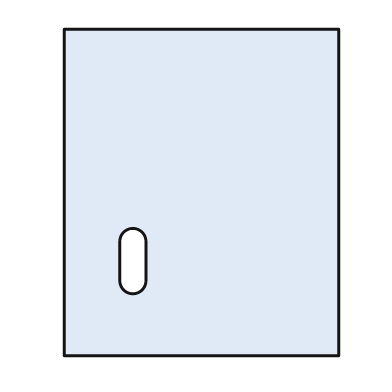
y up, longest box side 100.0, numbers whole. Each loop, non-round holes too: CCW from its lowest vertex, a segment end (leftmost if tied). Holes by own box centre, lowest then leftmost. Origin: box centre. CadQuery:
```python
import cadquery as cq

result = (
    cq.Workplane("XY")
    .moveTo(-42.0, -50.0)
    .lineTo(42.0, -50.0)
    .lineTo(42.0, 50.0)
    .lineTo(-42.0, 50.0)
    .close()
    .moveTo(-25.0, -27.0)
    .threePointArc((-21.0, -31.0), (-17.0, -27.0))
    .lineTo(-17.0, -15.0)
    .threePointArc((-21.0, -11.0), (-25.0, -15.0))
    .close()
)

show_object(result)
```